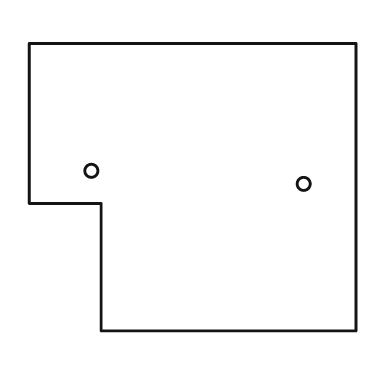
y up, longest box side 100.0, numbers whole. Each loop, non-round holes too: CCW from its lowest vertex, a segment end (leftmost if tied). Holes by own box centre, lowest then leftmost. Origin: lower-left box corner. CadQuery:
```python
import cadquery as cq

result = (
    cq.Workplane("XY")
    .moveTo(22.0, 0.0)
    .lineTo(100.0, 0.0)
    .lineTo(100.0, 88.0)
    .lineTo(0.0, 88.0)
    .lineTo(0.0, 39.0)
    .lineTo(22.0, 39.0)
    .close()
    .moveTo(84.0, 45.0)
    .circle(2.0)
    .moveTo(19.0, 49.0)
    .circle(2.0)
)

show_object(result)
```